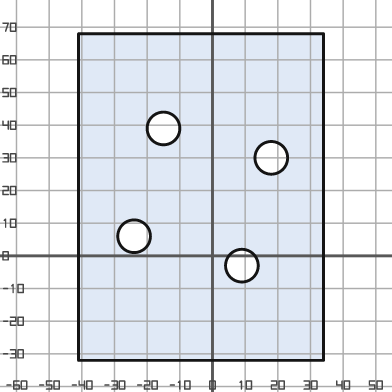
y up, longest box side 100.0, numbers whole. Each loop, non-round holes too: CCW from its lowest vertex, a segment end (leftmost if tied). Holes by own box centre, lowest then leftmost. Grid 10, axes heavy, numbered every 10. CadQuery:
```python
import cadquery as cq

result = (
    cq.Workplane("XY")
    .moveTo(-41.0, -32.0)
    .lineTo(34.0, -32.0)
    .lineTo(34.0, 68.0)
    .lineTo(-41.0, 68.0)
    .close()
    .moveTo(9.0, -3.0)
    .circle(5.0)
    .moveTo(-24.0, 6.0)
    .circle(5.0)
    .moveTo(18.0, 30.0)
    .circle(5.0)
    .moveTo(-15.0, 39.0)
    .circle(5.0)
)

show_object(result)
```